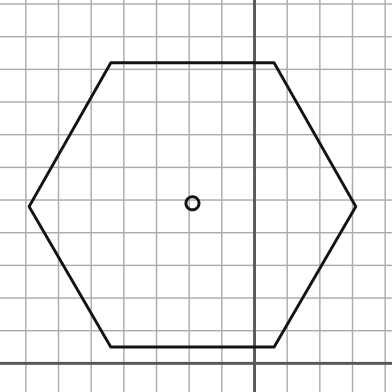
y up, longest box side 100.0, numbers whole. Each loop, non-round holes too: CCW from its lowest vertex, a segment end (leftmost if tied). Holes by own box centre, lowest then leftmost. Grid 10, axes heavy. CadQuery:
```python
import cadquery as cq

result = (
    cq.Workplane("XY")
    .moveTo(-44.0, 5.0)
    .lineTo(6.0, 5.0)
    .lineTo(31.0, 48.0)
    .lineTo(6.0, 92.0)
    .lineTo(-44.0, 92.0)
    .lineTo(-69.0, 48.0)
    .close()
    .moveTo(-19.0, 49.0)
    .circle(2.0)
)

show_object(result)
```